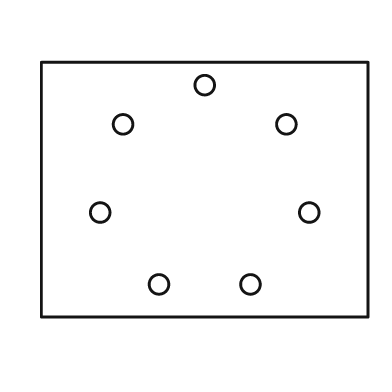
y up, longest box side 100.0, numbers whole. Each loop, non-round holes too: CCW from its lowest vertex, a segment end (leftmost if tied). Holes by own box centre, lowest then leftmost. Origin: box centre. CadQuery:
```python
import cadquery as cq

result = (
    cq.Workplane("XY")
    .moveTo(-50.0, -39.0)
    .lineTo(50.0, -39.0)
    .lineTo(50.0, 39.0)
    .lineTo(-50.0, 39.0)
    .close()
    .moveTo(-14.0, -29.0)
    .circle(3.0)
    .moveTo(14.0, -29.0)
    .circle(3.0)
    .moveTo(-32.0, -7.0)
    .circle(3.0)
    .moveTo(32.0, -7.0)
    .circle(3.0)
    .moveTo(-25.0, 20.0)
    .circle(3.0)
    .moveTo(25.0, 20.0)
    .circle(3.0)
    .moveTo(0.0, 32.0)
    .circle(3.0)
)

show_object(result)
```